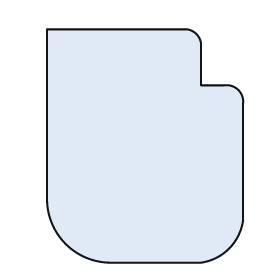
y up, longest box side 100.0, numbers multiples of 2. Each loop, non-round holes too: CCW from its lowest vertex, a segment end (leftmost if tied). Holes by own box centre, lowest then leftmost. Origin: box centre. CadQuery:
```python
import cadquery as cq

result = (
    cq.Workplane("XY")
    .moveTo(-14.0, -50.0)
    .lineTo(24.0, -50.0)
    .threePointArc((36.0, -44.0), (42.0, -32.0))
    .lineTo(42.0, 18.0)
    .threePointArc((40.0, 24.0), (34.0, 26.0))
    .lineTo(24.0, 26.0)
    .lineTo(24.0, 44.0)
    .threePointArc((22.0, 48.0), (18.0, 50.0))
    .lineTo(-42.0, 50.0)
    .lineTo(-42.0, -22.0)
    .threePointArc((-34.0, -42.0), (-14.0, -50.0))
    .close()
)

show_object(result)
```